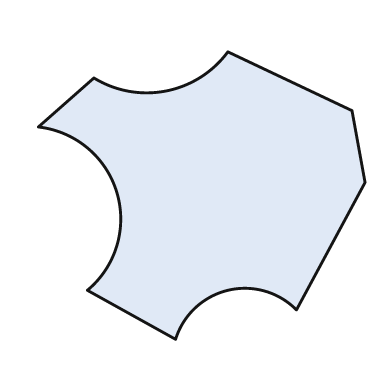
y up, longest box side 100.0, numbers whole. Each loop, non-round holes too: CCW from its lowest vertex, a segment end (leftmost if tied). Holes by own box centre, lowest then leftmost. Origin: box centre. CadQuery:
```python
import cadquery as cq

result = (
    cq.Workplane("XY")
    .moveTo(-8.0, -44.0)
    .threePointArc((8.0, -29.0), (29.0, -35.0))
    .lineTo(50.0, 4.0)
    .lineTo(46.0, 26.0)
    .lineTo(8.0, 44.0)
    .threePointArc((-11.0, 32.0), (-33.0, 36.0))
    .lineTo(-50.0, 21.0)
    .threePointArc((-26.0, 1.0), (-35.0, -29.0))
    .close()
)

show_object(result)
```